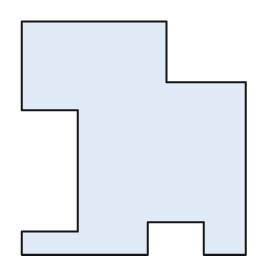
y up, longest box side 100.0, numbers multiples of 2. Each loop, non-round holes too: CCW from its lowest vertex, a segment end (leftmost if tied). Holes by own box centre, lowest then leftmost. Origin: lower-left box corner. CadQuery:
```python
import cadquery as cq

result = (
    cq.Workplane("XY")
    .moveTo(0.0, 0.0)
    .lineTo(54.0, 0.0)
    .lineTo(54.0, 14.0)
    .lineTo(78.0, 14.0)
    .lineTo(78.0, 0.0)
    .lineTo(96.0, 0.0)
    .lineTo(96.0, 74.0)
    .lineTo(62.0, 74.0)
    .lineTo(62.0, 100.0)
    .lineTo(0.0, 100.0)
    .lineTo(0.0, 62.0)
    .lineTo(24.0, 62.0)
    .lineTo(24.0, 10.0)
    .lineTo(0.0, 10.0)
    .close()
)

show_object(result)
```